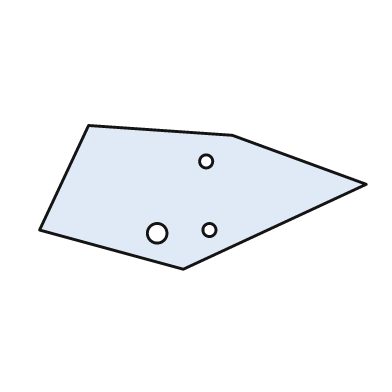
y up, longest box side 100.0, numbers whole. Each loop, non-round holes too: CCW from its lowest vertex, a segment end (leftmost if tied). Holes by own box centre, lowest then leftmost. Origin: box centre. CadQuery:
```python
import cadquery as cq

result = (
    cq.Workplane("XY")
    .moveTo(-6.0, -22.0)
    .lineTo(50.0, 4.0)
    .lineTo(9.0, 19.0)
    .lineTo(-35.0, 22.0)
    .lineTo(-50.0, -10.0)
    .close()
    .moveTo(-14.0, -11.0)
    .circle(3.0)
    .moveTo(2.0, -10.0)
    .circle(2.0)
    .moveTo(1.0, 11.0)
    .circle(2.0)
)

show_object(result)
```